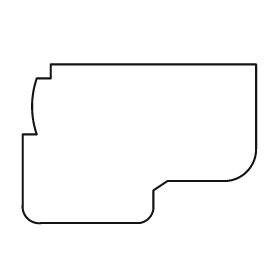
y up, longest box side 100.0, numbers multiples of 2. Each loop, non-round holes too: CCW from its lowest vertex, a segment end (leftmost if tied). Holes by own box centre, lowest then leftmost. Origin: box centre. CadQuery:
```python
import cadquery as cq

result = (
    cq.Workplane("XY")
    .moveTo(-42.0, -34.0)
    .lineTo(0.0, -34.0)
    .threePointArc((4.0, -32.0), (6.0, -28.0))
    .lineTo(6.0, -20.0)
    .lineTo(12.0, -16.0)
    .lineTo(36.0, -16.0)
    .threePointArc((46.0, -12.0), (50.0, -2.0))
    .lineTo(50.0, 34.0)
    .lineTo(-38.0, 34.0)
    .lineTo(-38.0, 28.0)
    .lineTo(-44.0, 28.0)
    .threePointArc((-46.0, 16.0), (-44.0, 4.0))
    .lineTo(-50.0, 4.0)
    .lineTo(-50.0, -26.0)
    .threePointArc((-48.0, -32.0), (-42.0, -34.0))
    .close()
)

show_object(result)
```